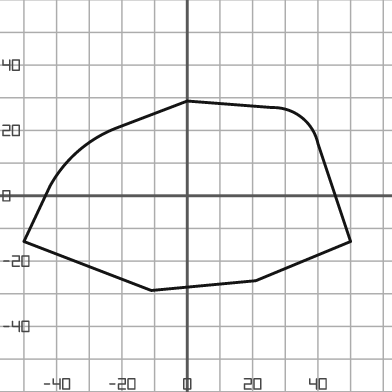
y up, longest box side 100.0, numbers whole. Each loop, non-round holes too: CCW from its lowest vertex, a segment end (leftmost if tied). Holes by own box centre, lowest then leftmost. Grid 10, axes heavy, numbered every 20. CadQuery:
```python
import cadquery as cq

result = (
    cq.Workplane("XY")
    .moveTo(-11.0, -29.0)
    .lineTo(21.0, -26.0)
    .lineTo(50.0, -14.0)
    .lineTo(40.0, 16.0)
    .threePointArc((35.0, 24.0), (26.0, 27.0))
    .lineTo(0.0, 29.0)
    .lineTo(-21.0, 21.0)
    .threePointArc((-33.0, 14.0), (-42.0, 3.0))
    .lineTo(-50.0, -14.0)
    .close()
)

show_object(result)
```